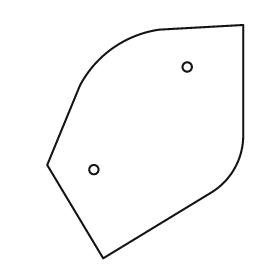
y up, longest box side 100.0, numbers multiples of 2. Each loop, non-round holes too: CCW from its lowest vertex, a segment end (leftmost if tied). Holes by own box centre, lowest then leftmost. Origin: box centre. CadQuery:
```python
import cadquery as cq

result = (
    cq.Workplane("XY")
    .moveTo(-18.0, -50.0)
    .lineTo(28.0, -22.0)
    .threePointArc((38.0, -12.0), (42.0, 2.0))
    .lineTo(42.0, 50.0)
    .lineTo(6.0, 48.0)
    .threePointArc((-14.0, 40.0), (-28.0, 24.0))
    .lineTo(-42.0, -10.0)
    .close()
    .moveTo(-22.0, -12.0)
    .circle(2.0)
    .moveTo(18.0, 32.0)
    .circle(2.0)
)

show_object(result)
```